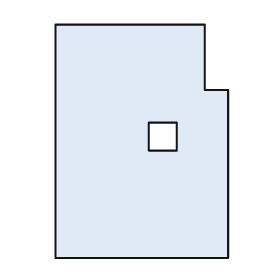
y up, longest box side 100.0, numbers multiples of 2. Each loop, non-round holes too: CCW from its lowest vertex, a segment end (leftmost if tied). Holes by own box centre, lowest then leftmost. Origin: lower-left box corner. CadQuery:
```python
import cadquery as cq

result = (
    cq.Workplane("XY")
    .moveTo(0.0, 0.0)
    .lineTo(74.0, 0.0)
    .lineTo(74.0, 72.0)
    .lineTo(64.0, 72.0)
    .lineTo(64.0, 100.0)
    .lineTo(0.0, 100.0)
    .close()
    .moveTo(40.0, 46.0)
    .lineTo(52.0, 46.0)
    .lineTo(52.0, 58.0)
    .lineTo(40.0, 58.0)
    .close()
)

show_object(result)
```